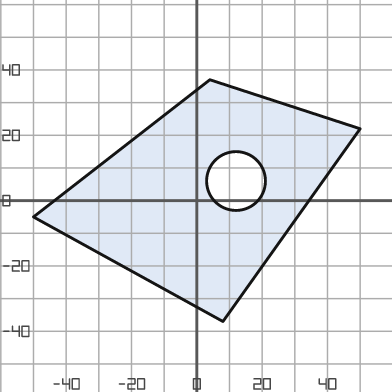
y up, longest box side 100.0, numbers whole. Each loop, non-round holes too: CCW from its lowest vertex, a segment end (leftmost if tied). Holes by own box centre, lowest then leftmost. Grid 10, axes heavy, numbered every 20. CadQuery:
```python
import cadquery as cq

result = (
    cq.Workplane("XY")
    .moveTo(8.0, -37.0)
    .lineTo(50.0, 22.0)
    .lineTo(4.0, 37.0)
    .lineTo(-50.0, -5.0)
    .close()
    .moveTo(12.0, 6.0)
    .circle(9.0)
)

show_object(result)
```